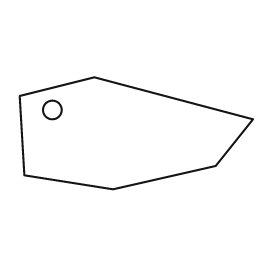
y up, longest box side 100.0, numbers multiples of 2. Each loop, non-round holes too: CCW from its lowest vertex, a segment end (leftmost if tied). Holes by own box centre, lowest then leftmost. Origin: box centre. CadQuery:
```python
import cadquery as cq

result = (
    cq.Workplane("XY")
    .moveTo(-10.0, -24.0)
    .lineTo(34.0, -14.0)
    .lineTo(50.0, 6.0)
    .lineTo(-18.0, 24.0)
    .lineTo(-50.0, 16.0)
    .lineTo(-48.0, -18.0)
    .close()
    .moveTo(-36.0, 10.0)
    .circle(4.0)
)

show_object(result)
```